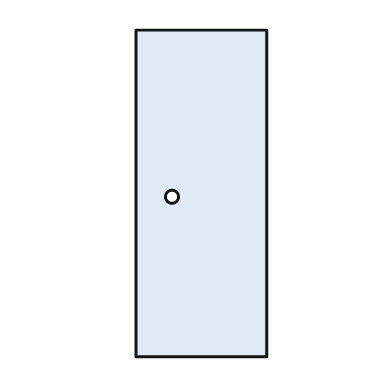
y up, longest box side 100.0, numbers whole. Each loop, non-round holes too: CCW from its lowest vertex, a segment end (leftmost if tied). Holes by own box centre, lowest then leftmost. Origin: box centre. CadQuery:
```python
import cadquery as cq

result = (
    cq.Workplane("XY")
    .moveTo(-20.0, -50.0)
    .lineTo(20.0, -50.0)
    .lineTo(20.0, 50.0)
    .lineTo(-20.0, 50.0)
    .close()
    .moveTo(-9.0, -1.0)
    .circle(2.0)
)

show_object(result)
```